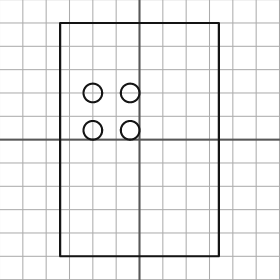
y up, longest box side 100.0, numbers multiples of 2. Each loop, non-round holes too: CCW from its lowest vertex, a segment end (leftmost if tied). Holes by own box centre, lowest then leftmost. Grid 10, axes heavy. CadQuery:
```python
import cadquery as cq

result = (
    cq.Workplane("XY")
    .moveTo(-34.0, -50.0)
    .lineTo(34.0, -50.0)
    .lineTo(34.0, 50.0)
    .lineTo(-34.0, 50.0)
    .close()
    .moveTo(-20.0, 4.0)
    .circle(4.0)
    .moveTo(-4.0, 4.0)
    .circle(4.0)
    .moveTo(-20.0, 20.0)
    .circle(4.0)
    .moveTo(-4.0, 20.0)
    .circle(4.0)
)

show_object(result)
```